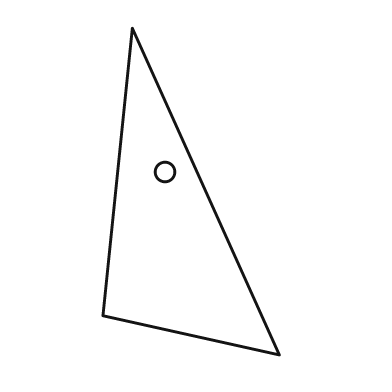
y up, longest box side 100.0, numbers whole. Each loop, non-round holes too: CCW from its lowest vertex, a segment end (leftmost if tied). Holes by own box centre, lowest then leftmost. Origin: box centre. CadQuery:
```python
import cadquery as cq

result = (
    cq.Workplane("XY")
    .moveTo(27.0, -50.0)
    .lineTo(-18.0, 50.0)
    .lineTo(-27.0, -38.0)
    .close()
    .moveTo(-8.0, 6.0)
    .circle(3.0)
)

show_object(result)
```